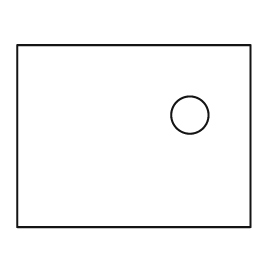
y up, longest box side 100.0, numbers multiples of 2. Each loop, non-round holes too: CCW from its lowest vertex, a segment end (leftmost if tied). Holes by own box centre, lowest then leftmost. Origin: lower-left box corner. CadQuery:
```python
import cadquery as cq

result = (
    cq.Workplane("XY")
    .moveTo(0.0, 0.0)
    .lineTo(100.0, 0.0)
    .lineTo(100.0, 78.0)
    .lineTo(0.0, 78.0)
    .close()
    .moveTo(74.0, 48.0)
    .circle(8.0)
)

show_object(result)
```